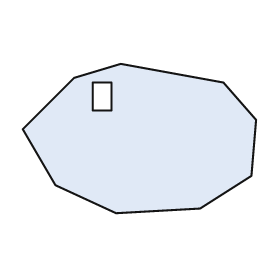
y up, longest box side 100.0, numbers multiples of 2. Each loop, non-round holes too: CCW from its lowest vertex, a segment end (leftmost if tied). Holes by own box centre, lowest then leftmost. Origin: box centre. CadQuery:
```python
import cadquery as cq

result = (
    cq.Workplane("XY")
    .moveTo(-10.0, -32.0)
    .lineTo(26.0, -30.0)
    .lineTo(48.0, -16.0)
    .lineTo(50.0, 8.0)
    .lineTo(36.0, 24.0)
    .lineTo(-8.0, 32.0)
    .lineTo(-28.0, 26.0)
    .lineTo(-50.0, 4.0)
    .lineTo(-36.0, -20.0)
    .close()
    .moveTo(-20.0, 12.0)
    .lineTo(-12.0, 12.0)
    .lineTo(-12.0, 24.0)
    .lineTo(-20.0, 24.0)
    .close()
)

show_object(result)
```